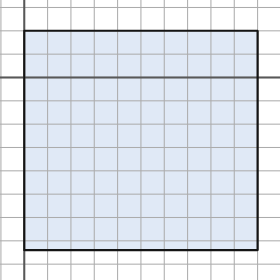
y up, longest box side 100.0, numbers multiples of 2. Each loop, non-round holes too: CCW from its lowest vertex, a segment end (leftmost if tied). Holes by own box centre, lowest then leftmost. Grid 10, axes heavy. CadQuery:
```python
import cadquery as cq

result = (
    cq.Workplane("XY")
    .moveTo(0.0, -74.0)
    .lineTo(100.0, -74.0)
    .lineTo(100.0, 20.0)
    .lineTo(0.0, 20.0)
    .close()
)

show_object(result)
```